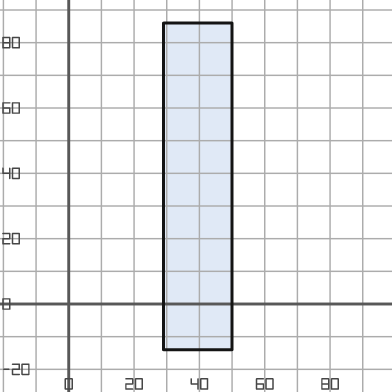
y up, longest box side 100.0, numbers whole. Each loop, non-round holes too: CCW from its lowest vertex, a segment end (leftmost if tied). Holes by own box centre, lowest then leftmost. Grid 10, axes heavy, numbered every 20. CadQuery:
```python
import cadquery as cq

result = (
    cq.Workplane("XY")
    .moveTo(29.0, -14.0)
    .lineTo(50.0, -14.0)
    .lineTo(50.0, 86.0)
    .lineTo(29.0, 86.0)
    .close()
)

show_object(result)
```